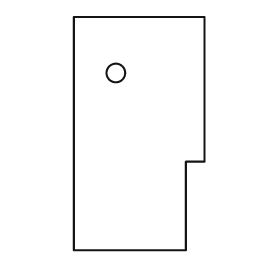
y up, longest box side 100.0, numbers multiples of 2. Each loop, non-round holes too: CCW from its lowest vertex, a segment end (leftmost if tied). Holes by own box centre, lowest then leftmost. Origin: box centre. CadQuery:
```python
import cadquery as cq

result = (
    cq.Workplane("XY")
    .moveTo(-28.0, -50.0)
    .lineTo(20.0, -50.0)
    .lineTo(20.0, -12.0)
    .lineTo(28.0, -12.0)
    .lineTo(28.0, 50.0)
    .lineTo(-28.0, 50.0)
    .close()
    .moveTo(-10.0, 26.0)
    .circle(4.0)
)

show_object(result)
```